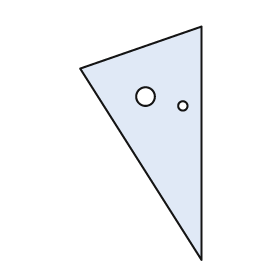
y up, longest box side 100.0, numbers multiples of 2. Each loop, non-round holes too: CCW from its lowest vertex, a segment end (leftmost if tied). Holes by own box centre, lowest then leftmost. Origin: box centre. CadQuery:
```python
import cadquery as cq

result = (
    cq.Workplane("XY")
    .moveTo(26.0, -50.0)
    .lineTo(26.0, 50.0)
    .lineTo(-26.0, 32.0)
    .close()
    .moveTo(18.0, 16.0)
    .circle(2.0)
    .moveTo(2.0, 20.0)
    .circle(4.0)
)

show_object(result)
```